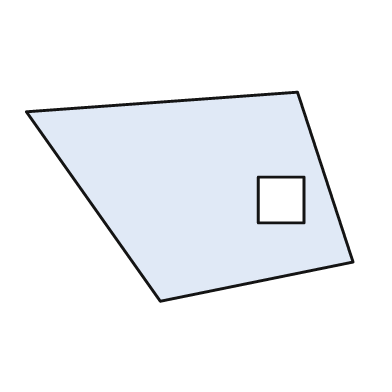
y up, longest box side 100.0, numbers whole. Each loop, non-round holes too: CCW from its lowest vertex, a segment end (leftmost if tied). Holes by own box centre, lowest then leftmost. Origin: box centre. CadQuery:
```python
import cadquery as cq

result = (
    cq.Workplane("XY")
    .moveTo(-9.0, -32.0)
    .lineTo(50.0, -20.0)
    .lineTo(33.0, 32.0)
    .lineTo(-50.0, 26.0)
    .close()
    .moveTo(21.0, -8.0)
    .lineTo(35.0, -8.0)
    .lineTo(35.0, 6.0)
    .lineTo(21.0, 6.0)
    .close()
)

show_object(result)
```